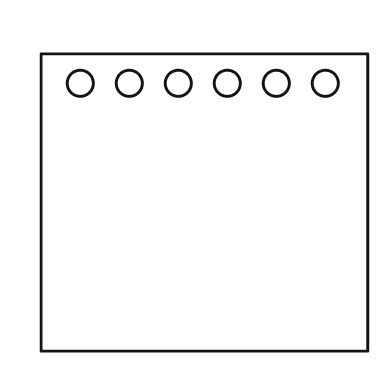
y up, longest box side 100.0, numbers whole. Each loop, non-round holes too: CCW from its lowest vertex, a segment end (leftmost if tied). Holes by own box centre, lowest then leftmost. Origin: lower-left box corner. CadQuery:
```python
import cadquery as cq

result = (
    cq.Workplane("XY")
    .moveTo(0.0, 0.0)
    .lineTo(100.0, 0.0)
    .lineTo(100.0, 91.0)
    .lineTo(0.0, 91.0)
    .close()
    .moveTo(12.0, 82.0)
    .circle(4.0)
    .moveTo(27.0, 82.0)
    .circle(4.0)
    .moveTo(42.0, 82.0)
    .circle(4.0)
    .moveTo(57.0, 82.0)
    .circle(4.0)
    .moveTo(72.0, 82.0)
    .circle(4.0)
    .moveTo(87.0, 82.0)
    .circle(4.0)
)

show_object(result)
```